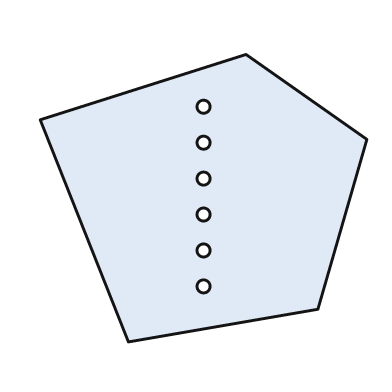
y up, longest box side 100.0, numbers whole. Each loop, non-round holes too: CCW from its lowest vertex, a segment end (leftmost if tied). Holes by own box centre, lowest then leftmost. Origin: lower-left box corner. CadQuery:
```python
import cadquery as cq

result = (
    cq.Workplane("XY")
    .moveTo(27.0, 0.0)
    .lineTo(85.0, 10.0)
    .lineTo(100.0, 62.0)
    .lineTo(63.0, 88.0)
    .lineTo(0.0, 68.0)
    .close()
    .moveTo(50.0, 17.0)
    .circle(2.0)
    .moveTo(50.0, 28.0)
    .circle(2.0)
    .moveTo(50.0, 39.0)
    .circle(2.0)
    .moveTo(50.0, 50.0)
    .circle(2.0)
    .moveTo(50.0, 61.0)
    .circle(2.0)
    .moveTo(50.0, 72.0)
    .circle(2.0)
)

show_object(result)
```